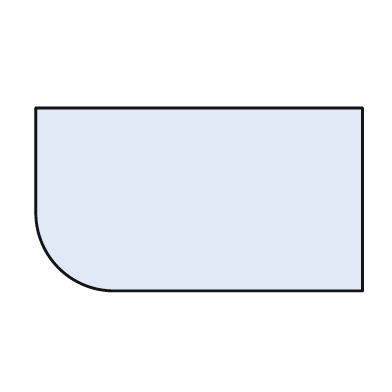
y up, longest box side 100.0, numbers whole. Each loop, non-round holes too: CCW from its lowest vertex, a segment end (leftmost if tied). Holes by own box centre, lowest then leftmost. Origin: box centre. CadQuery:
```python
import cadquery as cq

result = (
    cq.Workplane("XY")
    .moveTo(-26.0, -28.0)
    .lineTo(50.0, -28.0)
    .lineTo(50.0, 28.0)
    .lineTo(-50.0, 28.0)
    .lineTo(-50.0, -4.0)
    .threePointArc((-43.0, -21.0), (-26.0, -28.0))
    .close()
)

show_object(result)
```